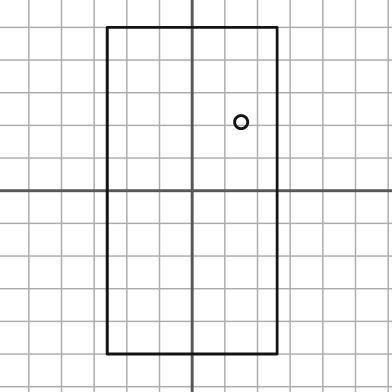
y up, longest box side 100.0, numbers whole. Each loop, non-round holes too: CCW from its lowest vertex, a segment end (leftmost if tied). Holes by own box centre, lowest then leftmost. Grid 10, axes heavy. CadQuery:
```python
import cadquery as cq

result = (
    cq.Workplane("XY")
    .moveTo(-26.0, -50.0)
    .lineTo(26.0, -50.0)
    .lineTo(26.0, 50.0)
    .lineTo(-26.0, 50.0)
    .close()
    .moveTo(15.0, 21.0)
    .circle(2.0)
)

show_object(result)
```